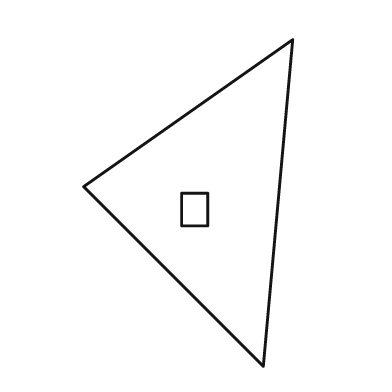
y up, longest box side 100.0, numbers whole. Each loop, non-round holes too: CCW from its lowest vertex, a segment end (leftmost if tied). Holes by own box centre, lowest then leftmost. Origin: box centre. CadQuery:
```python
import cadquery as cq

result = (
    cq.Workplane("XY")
    .moveTo(23.0, -50.0)
    .lineTo(32.0, 50.0)
    .lineTo(-32.0, 5.0)
    .close()
    .moveTo(-2.0, -7.0)
    .lineTo(6.0, -7.0)
    .lineTo(6.0, 3.0)
    .lineTo(-2.0, 3.0)
    .close()
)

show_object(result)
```